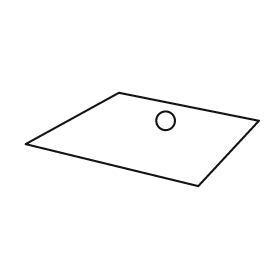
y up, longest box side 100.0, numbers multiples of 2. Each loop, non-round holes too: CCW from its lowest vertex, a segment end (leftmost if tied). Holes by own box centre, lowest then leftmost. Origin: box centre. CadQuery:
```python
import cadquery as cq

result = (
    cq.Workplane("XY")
    .moveTo(24.0, -20.0)
    .lineTo(50.0, 8.0)
    .lineTo(-10.0, 20.0)
    .lineTo(-50.0, -2.0)
    .close()
    .moveTo(10.0, 8.0)
    .circle(4.0)
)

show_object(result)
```